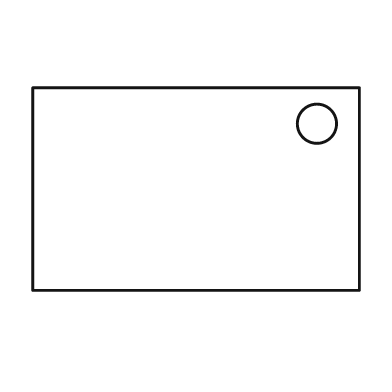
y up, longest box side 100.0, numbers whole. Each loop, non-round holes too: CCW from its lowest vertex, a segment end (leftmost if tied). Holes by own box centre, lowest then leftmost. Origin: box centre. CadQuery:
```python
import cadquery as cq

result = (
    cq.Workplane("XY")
    .moveTo(-50.0, -31.0)
    .lineTo(50.0, -31.0)
    .lineTo(50.0, 31.0)
    .lineTo(-50.0, 31.0)
    .close()
    .moveTo(37.0, 20.0)
    .circle(6.0)
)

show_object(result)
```